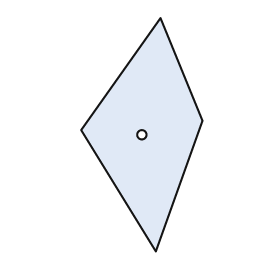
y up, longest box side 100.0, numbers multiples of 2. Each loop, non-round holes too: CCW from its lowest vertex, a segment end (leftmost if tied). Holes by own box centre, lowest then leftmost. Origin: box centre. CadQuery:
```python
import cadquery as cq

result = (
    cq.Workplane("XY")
    .moveTo(6.0, -50.0)
    .lineTo(26.0, 6.0)
    .lineTo(8.0, 50.0)
    .lineTo(-26.0, 2.0)
    .close()
    .moveTo(0.0, 0.0)
    .circle(2.0)
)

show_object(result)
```